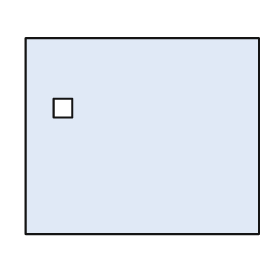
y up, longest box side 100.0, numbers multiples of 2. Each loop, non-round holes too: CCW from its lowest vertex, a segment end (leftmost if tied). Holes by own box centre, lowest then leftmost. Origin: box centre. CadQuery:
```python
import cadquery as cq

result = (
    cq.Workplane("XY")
    .moveTo(-50.0, -42.0)
    .lineTo(50.0, -42.0)
    .lineTo(50.0, 42.0)
    .lineTo(-50.0, 42.0)
    .close()
    .moveTo(-38.0, 8.0)
    .lineTo(-30.0, 8.0)
    .lineTo(-30.0, 16.0)
    .lineTo(-38.0, 16.0)
    .close()
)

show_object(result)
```